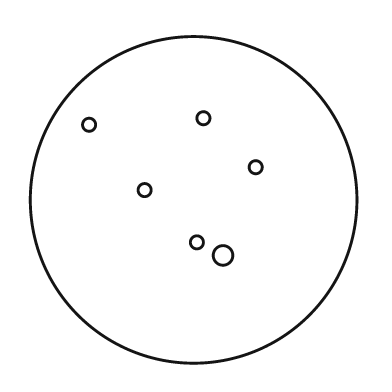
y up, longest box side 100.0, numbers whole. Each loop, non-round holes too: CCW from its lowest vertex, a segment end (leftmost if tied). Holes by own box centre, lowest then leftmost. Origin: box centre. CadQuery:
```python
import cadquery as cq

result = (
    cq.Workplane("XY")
    .moveTo(0.0, 0.0)
    .circle(50.0)
    .moveTo(9.0, -17.0)
    .circle(3.0)
    .moveTo(1.0, -13.0)
    .circle(2.0)
    .moveTo(-15.0, 3.0)
    .circle(2.0)
    .moveTo(19.0, 10.0)
    .circle(2.0)
    .moveTo(-32.0, 23.0)
    .circle(2.0)
    .moveTo(3.0, 25.0)
    .circle(2.0)
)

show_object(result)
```